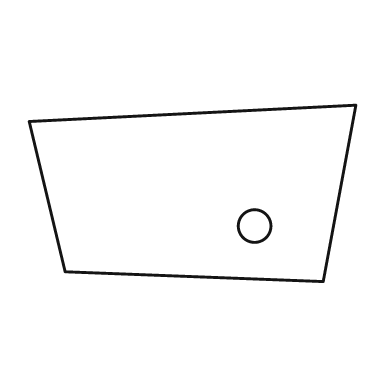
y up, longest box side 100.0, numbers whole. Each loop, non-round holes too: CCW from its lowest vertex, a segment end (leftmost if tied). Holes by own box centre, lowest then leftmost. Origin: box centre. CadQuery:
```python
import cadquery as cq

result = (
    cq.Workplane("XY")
    .moveTo(40.0, -27.0)
    .lineTo(50.0, 27.0)
    .lineTo(-50.0, 22.0)
    .lineTo(-39.0, -24.0)
    .close()
    .moveTo(19.0, -10.0)
    .circle(5.0)
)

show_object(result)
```